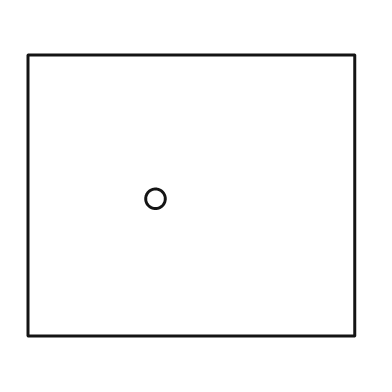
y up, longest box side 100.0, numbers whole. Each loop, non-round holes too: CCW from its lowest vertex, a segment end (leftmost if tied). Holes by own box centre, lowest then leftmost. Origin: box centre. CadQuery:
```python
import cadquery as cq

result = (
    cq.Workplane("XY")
    .moveTo(-50.0, -43.0)
    .lineTo(50.0, -43.0)
    .lineTo(50.0, 43.0)
    .lineTo(-50.0, 43.0)
    .close()
    .moveTo(-11.0, -1.0)
    .circle(3.0)
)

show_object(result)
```